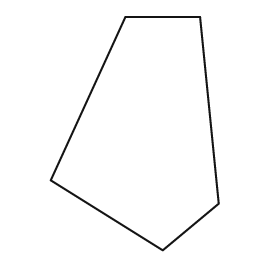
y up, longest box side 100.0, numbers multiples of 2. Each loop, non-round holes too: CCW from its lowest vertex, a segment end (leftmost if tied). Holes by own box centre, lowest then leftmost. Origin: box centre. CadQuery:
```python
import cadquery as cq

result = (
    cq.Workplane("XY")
    .moveTo(12.0, -50.0)
    .lineTo(36.0, -30.0)
    .lineTo(28.0, 50.0)
    .lineTo(-4.0, 50.0)
    .lineTo(-36.0, -20.0)
    .close()
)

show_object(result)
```